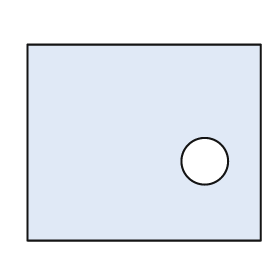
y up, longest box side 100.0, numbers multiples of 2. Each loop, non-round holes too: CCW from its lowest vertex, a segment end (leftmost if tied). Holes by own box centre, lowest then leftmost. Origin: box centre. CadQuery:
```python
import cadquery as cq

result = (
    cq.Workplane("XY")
    .moveTo(-50.0, -42.0)
    .lineTo(50.0, -42.0)
    .lineTo(50.0, 42.0)
    .lineTo(-50.0, 42.0)
    .close()
    .moveTo(26.0, -8.0)
    .circle(10.0)
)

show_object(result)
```